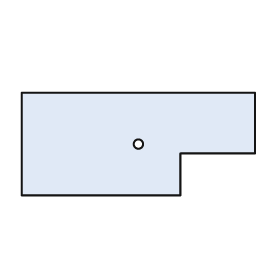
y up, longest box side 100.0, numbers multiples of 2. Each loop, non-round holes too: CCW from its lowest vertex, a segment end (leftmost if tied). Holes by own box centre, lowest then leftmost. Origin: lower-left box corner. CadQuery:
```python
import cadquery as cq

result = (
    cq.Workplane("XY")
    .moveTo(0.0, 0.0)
    .lineTo(68.0, 0.0)
    .lineTo(68.0, 18.0)
    .lineTo(100.0, 18.0)
    .lineTo(100.0, 44.0)
    .lineTo(0.0, 44.0)
    .close()
    .moveTo(50.0, 22.0)
    .circle(2.0)
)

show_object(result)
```